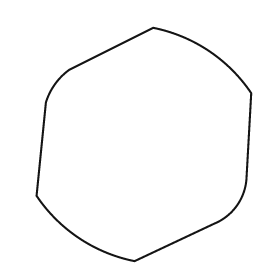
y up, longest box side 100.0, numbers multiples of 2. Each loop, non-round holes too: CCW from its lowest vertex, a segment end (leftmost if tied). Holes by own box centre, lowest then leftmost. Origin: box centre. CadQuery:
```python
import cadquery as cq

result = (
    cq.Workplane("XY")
    .moveTo(-4.0, -50.0)
    .lineTo(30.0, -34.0)
    .threePointArc((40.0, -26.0), (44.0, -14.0))
    .lineTo(46.0, 22.0)
    .threePointArc((28.0, 40.0), (4.0, 50.0))
    .lineTo(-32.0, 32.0)
    .threePointArc((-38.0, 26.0), (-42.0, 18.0))
    .lineTo(-46.0, -22.0)
    .threePointArc((-28.0, -40.0), (-4.0, -50.0))
    .close()
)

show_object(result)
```